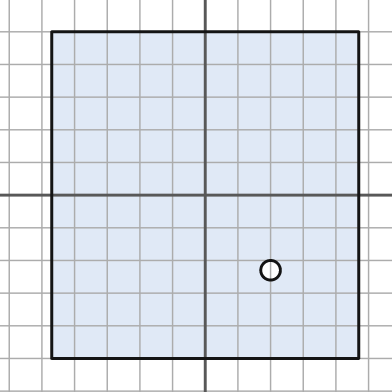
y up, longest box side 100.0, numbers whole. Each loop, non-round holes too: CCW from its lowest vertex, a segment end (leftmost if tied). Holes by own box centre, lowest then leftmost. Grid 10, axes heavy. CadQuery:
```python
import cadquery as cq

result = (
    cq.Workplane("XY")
    .moveTo(-47.0, -50.0)
    .lineTo(47.0, -50.0)
    .lineTo(47.0, 50.0)
    .lineTo(-47.0, 50.0)
    .close()
    .moveTo(20.0, -23.0)
    .circle(3.0)
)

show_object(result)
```